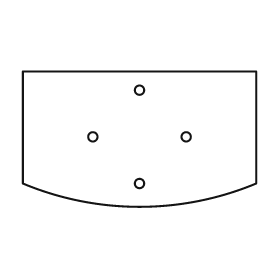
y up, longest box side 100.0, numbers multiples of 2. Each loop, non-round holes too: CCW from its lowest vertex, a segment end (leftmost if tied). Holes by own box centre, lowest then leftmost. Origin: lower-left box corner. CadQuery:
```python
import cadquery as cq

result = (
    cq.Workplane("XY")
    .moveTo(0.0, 10.0)
    .threePointArc((50.0, 0.0), (100.0, 10.0))
    .lineTo(100.0, 58.0)
    .lineTo(0.0, 58.0)
    .close()
    .moveTo(50.0, 10.0)
    .circle(2.0)
    .moveTo(30.0, 30.0)
    .circle(2.0)
    .moveTo(70.0, 30.0)
    .circle(2.0)
    .moveTo(50.0, 50.0)
    .circle(2.0)
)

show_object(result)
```